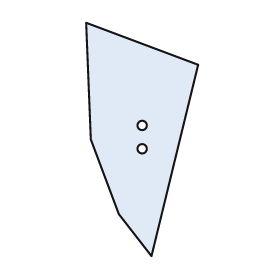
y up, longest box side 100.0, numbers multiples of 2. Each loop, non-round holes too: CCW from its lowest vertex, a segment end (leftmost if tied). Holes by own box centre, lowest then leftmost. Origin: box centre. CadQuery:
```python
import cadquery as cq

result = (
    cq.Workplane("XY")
    .moveTo(4.0, -50.0)
    .lineTo(24.0, 32.0)
    .lineTo(-24.0, 50.0)
    .lineTo(-22.0, 0.0)
    .lineTo(-10.0, -32.0)
    .close()
    .moveTo(0.0, -4.0)
    .circle(2.0)
    .moveTo(0.0, 6.0)
    .circle(2.0)
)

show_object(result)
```